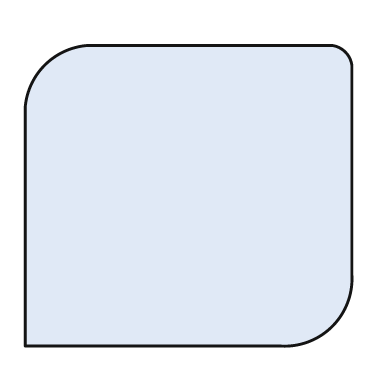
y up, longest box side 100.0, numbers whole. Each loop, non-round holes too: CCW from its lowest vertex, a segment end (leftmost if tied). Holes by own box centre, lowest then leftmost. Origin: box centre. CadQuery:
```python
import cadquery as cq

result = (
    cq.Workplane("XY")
    .moveTo(-50.0, -46.0)
    .lineTo(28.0, -46.0)
    .threePointArc((44.0, -40.0), (50.0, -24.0))
    .lineTo(50.0, 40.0)
    .threePointArc((48.0, 44.0), (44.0, 46.0))
    .lineTo(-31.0, 46.0)
    .threePointArc((-44.0, 40.0), (-50.0, 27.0))
    .close()
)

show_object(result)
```